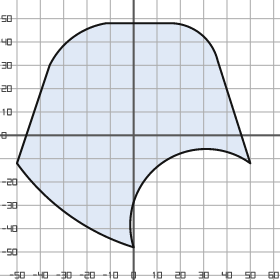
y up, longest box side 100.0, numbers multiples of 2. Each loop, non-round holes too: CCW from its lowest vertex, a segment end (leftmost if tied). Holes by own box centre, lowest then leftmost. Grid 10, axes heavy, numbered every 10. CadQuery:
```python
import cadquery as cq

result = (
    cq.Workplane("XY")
    .moveTo(0.0, -48.0)
    .threePointArc((12.0, -12.0), (50.0, -12.0))
    .lineTo(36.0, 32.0)
    .threePointArc((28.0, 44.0), (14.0, 48.0))
    .lineTo(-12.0, 48.0)
    .threePointArc((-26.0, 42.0), (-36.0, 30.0))
    .lineTo(-50.0, -12.0)
    .threePointArc((-28.0, -34.0), (0.0, -48.0))
    .close()
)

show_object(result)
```